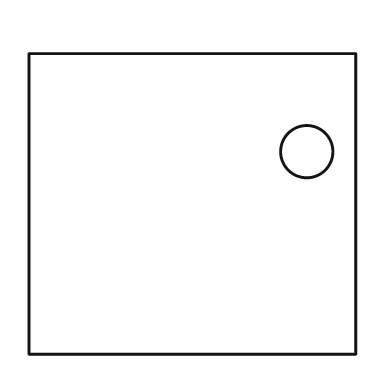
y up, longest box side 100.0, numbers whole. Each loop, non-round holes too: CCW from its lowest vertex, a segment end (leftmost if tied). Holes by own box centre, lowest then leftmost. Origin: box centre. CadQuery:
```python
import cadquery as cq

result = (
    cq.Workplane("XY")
    .moveTo(-50.0, -46.0)
    .lineTo(50.0, -46.0)
    .lineTo(50.0, 46.0)
    .lineTo(-50.0, 46.0)
    .close()
    .moveTo(35.0, 16.0)
    .circle(8.0)
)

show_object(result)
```